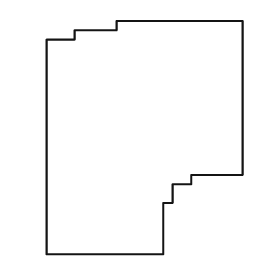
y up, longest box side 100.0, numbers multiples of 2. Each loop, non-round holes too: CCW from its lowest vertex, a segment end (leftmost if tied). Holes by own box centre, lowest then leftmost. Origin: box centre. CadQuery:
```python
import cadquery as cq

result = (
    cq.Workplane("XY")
    .moveTo(-42.0, -50.0)
    .lineTo(8.0, -50.0)
    .lineTo(8.0, -28.0)
    .lineTo(12.0, -28.0)
    .lineTo(12.0, -20.0)
    .lineTo(20.0, -20.0)
    .lineTo(20.0, -16.0)
    .lineTo(42.0, -16.0)
    .lineTo(42.0, 50.0)
    .lineTo(-12.0, 50.0)
    .lineTo(-12.0, 46.0)
    .lineTo(-30.0, 46.0)
    .lineTo(-30.0, 42.0)
    .lineTo(-42.0, 42.0)
    .close()
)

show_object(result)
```